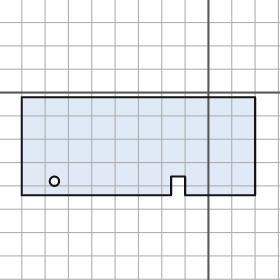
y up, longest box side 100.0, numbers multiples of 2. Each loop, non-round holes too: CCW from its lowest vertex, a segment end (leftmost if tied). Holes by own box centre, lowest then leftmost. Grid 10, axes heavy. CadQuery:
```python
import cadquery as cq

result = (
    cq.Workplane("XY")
    .moveTo(-80.0, -44.0)
    .lineTo(-16.0, -44.0)
    .lineTo(-16.0, -36.0)
    .lineTo(-10.0, -36.0)
    .lineTo(-10.0, -44.0)
    .lineTo(20.0, -44.0)
    .lineTo(20.0, -2.0)
    .lineTo(-80.0, -2.0)
    .close()
    .moveTo(-66.0, -38.0)
    .circle(2.0)
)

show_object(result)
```